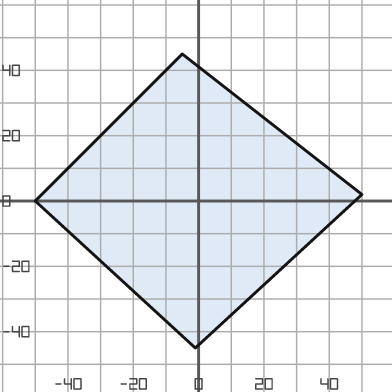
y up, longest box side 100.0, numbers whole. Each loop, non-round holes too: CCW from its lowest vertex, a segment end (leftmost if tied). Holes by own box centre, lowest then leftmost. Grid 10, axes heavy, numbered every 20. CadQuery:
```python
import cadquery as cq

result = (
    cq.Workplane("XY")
    .moveTo(-1.0, -45.0)
    .lineTo(50.0, 2.0)
    .lineTo(-5.0, 45.0)
    .lineTo(-50.0, 0.0)
    .close()
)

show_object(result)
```